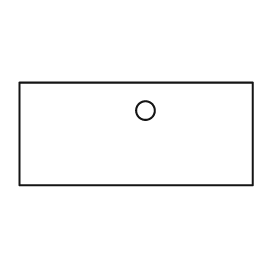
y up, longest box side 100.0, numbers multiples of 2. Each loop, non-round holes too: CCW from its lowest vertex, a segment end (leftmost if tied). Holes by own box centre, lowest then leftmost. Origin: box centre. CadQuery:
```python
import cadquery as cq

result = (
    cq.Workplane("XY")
    .moveTo(-50.0, -22.0)
    .lineTo(50.0, -22.0)
    .lineTo(50.0, 22.0)
    .lineTo(-50.0, 22.0)
    .close()
    .moveTo(4.0, 10.0)
    .circle(4.0)
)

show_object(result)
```